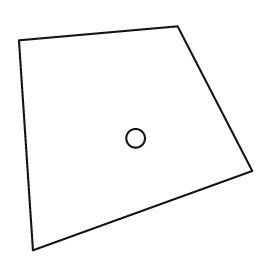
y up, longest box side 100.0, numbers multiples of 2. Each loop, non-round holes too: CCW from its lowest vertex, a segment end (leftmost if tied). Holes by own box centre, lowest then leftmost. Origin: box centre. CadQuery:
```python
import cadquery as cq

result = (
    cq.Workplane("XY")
    .moveTo(-44.0, -48.0)
    .lineTo(50.0, -14.0)
    .lineTo(18.0, 48.0)
    .lineTo(-50.0, 42.0)
    .close()
    .moveTo(0.0, 0.0)
    .circle(4.0)
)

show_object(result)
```